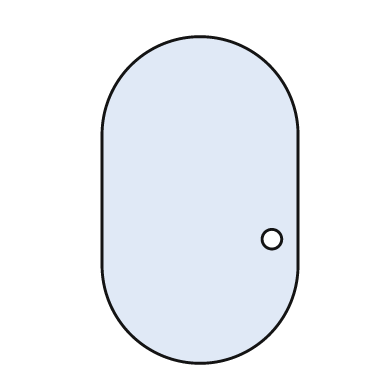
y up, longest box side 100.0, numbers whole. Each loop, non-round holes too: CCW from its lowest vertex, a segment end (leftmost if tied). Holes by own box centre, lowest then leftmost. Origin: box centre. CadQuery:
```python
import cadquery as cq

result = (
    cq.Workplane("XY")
    .moveTo(-30.0, -20.0)
    .threePointArc((0.0, -50.0), (30.0, -20.0))
    .lineTo(30.0, 20.0)
    .threePointArc((0.0, 50.0), (-30.0, 20.0))
    .close()
    .moveTo(22.0, -12.0)
    .circle(3.0)
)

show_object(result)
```